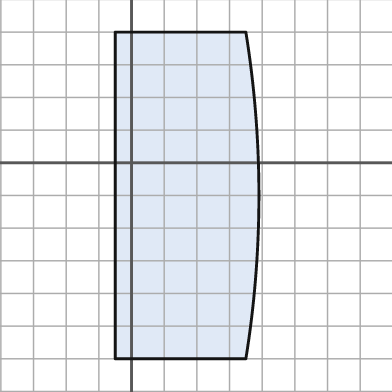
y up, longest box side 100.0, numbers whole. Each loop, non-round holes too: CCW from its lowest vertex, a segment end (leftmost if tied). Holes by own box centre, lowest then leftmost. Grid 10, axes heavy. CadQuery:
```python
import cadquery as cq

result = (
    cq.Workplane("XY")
    .moveTo(-5.0, -60.0)
    .lineTo(35.0, -60.0)
    .threePointArc((39.0, -10.0), (35.0, 40.0))
    .lineTo(-5.0, 40.0)
    .close()
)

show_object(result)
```